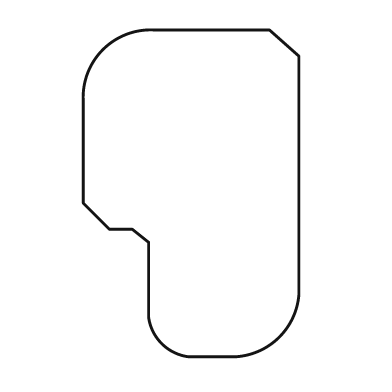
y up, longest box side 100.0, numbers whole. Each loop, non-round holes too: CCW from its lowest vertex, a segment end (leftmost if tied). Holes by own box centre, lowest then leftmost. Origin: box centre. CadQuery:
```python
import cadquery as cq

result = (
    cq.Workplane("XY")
    .moveTo(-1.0, -50.0)
    .lineTo(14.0, -50.0)
    .threePointArc((27.0, -44.0), (33.0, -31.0))
    .lineTo(33.0, 42.0)
    .lineTo(24.0, 50.0)
    .lineTo(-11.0, 50.0)
    .threePointArc((-27.0, 44.0), (-33.0, 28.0))
    .lineTo(-33.0, -3.0)
    .lineTo(-25.0, -11.0)
    .lineTo(-18.0, -11.0)
    .lineTo(-13.0, -15.0)
    .lineTo(-13.0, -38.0)
    .threePointArc((-9.0, -46.0), (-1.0, -50.0))
    .close()
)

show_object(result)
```